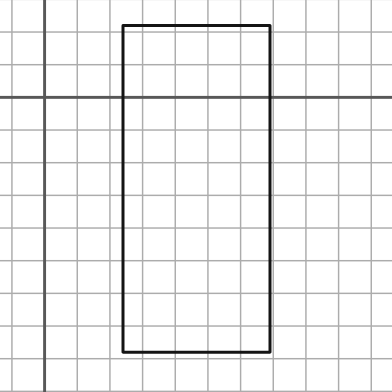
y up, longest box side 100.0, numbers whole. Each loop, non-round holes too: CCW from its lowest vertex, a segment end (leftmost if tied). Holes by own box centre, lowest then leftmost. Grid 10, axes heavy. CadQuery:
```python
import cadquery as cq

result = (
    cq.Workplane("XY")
    .moveTo(24.0, -78.0)
    .lineTo(69.0, -78.0)
    .lineTo(69.0, 22.0)
    .lineTo(24.0, 22.0)
    .close()
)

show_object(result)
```